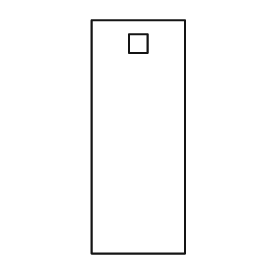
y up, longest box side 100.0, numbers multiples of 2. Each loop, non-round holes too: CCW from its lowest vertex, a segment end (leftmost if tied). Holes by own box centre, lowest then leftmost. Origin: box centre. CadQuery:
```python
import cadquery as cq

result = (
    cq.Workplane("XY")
    .moveTo(-20.0, -50.0)
    .lineTo(20.0, -50.0)
    .lineTo(20.0, 50.0)
    .lineTo(-20.0, 50.0)
    .close()
    .moveTo(-4.0, 36.0)
    .lineTo(4.0, 36.0)
    .lineTo(4.0, 44.0)
    .lineTo(-4.0, 44.0)
    .close()
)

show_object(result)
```